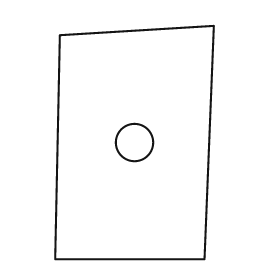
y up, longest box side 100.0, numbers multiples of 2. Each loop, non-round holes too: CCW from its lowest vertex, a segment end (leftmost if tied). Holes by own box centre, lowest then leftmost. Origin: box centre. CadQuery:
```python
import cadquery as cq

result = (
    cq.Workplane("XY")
    .moveTo(-34.0, -50.0)
    .lineTo(30.0, -50.0)
    .lineTo(34.0, 50.0)
    .lineTo(-32.0, 46.0)
    .close()
    .moveTo(0.0, 0.0)
    .circle(8.0)
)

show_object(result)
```